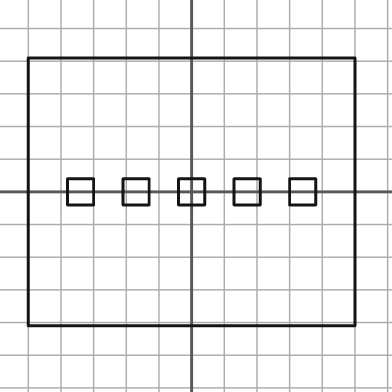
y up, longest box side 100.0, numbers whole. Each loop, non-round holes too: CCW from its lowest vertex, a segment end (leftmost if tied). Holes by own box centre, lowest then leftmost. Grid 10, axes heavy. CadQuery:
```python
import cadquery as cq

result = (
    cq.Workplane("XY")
    .moveTo(-50.0, -41.0)
    .lineTo(50.0, -41.0)
    .lineTo(50.0, 41.0)
    .lineTo(-50.0, 41.0)
    .close()
    .moveTo(-38.0, -4.0)
    .lineTo(-30.0, -4.0)
    .lineTo(-30.0, 4.0)
    .lineTo(-38.0, 4.0)
    .close()
    .moveTo(-21.0, -4.0)
    .lineTo(-13.0, -4.0)
    .lineTo(-13.0, 4.0)
    .lineTo(-21.0, 4.0)
    .close()
    .moveTo(-4.0, -4.0)
    .lineTo(4.0, -4.0)
    .lineTo(4.0, 4.0)
    .lineTo(-4.0, 4.0)
    .close()
    .moveTo(13.0, -4.0)
    .lineTo(21.0, -4.0)
    .lineTo(21.0, 4.0)
    .lineTo(13.0, 4.0)
    .close()
    .moveTo(30.0, -4.0)
    .lineTo(38.0, -4.0)
    .lineTo(38.0, 4.0)
    .lineTo(30.0, 4.0)
    .close()
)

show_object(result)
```